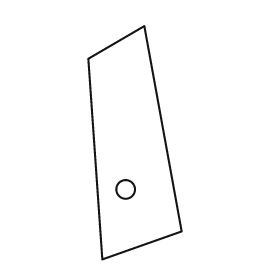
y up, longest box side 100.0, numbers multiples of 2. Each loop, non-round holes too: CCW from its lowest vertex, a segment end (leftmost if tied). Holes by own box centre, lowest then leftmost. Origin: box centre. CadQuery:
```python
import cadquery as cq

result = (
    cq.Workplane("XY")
    .moveTo(-14.0, -50.0)
    .lineTo(20.0, -38.0)
    .lineTo(4.0, 50.0)
    .lineTo(-20.0, 36.0)
    .close()
    .moveTo(-4.0, -20.0)
    .circle(4.0)
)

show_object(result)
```